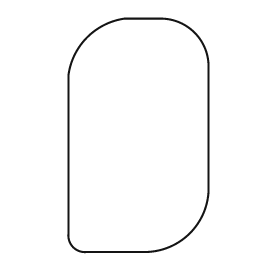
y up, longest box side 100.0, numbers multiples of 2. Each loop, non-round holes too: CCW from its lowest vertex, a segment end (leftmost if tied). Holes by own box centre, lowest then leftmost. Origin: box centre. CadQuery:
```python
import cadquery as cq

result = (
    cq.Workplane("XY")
    .moveTo(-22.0, -50.0)
    .lineTo(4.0, -50.0)
    .threePointArc((22.0, -42.0), (30.0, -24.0))
    .lineTo(30.0, 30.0)
    .threePointArc((24.0, 44.0), (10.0, 50.0))
    .lineTo(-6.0, 50.0)
    .threePointArc((-22.0, 42.0), (-30.0, 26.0))
    .lineTo(-30.0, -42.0)
    .threePointArc((-28.0, -48.0), (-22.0, -50.0))
    .close()
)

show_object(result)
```